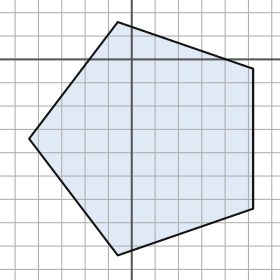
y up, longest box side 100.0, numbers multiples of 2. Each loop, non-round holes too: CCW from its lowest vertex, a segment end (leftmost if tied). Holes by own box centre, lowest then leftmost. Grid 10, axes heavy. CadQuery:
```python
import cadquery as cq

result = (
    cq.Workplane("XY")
    .moveTo(-6.0, -84.0)
    .lineTo(52.0, -64.0)
    .lineTo(52.0, -4.0)
    .lineTo(-6.0, 16.0)
    .lineTo(-44.0, -34.0)
    .close()
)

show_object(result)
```